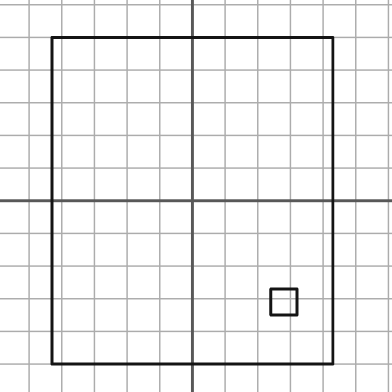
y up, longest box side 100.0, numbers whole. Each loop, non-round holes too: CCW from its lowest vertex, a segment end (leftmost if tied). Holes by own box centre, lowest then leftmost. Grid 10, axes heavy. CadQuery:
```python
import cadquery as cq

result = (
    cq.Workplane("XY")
    .moveTo(-43.0, -50.0)
    .lineTo(43.0, -50.0)
    .lineTo(43.0, 50.0)
    .lineTo(-43.0, 50.0)
    .close()
    .moveTo(24.0, -35.0)
    .lineTo(32.0, -35.0)
    .lineTo(32.0, -27.0)
    .lineTo(24.0, -27.0)
    .close()
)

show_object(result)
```